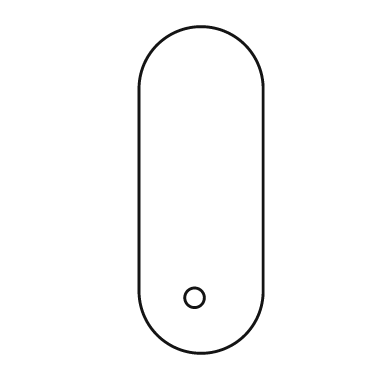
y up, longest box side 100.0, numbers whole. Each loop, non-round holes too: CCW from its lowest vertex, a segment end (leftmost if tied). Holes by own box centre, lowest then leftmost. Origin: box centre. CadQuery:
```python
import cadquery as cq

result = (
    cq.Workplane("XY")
    .moveTo(-19.0, -31.0)
    .threePointArc((0.0, -50.0), (19.0, -31.0))
    .lineTo(19.0, 31.0)
    .threePointArc((0.0, 50.0), (-19.0, 31.0))
    .close()
    .moveTo(-2.0, -33.0)
    .circle(3.0)
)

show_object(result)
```